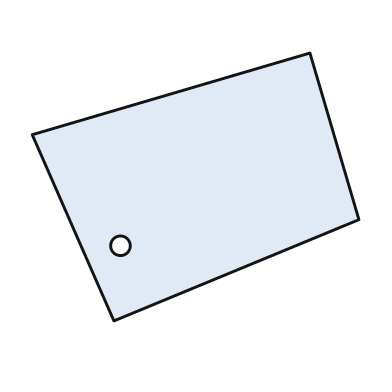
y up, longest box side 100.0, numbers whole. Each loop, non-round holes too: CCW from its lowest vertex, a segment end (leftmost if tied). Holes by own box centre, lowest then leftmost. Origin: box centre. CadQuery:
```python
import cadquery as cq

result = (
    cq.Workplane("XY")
    .moveTo(-25.0, -41.0)
    .lineTo(50.0, -10.0)
    .lineTo(35.0, 41.0)
    .lineTo(-50.0, 16.0)
    .close()
    .moveTo(-23.0, -18.0)
    .circle(3.0)
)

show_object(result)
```